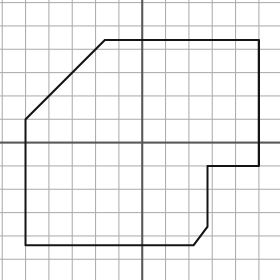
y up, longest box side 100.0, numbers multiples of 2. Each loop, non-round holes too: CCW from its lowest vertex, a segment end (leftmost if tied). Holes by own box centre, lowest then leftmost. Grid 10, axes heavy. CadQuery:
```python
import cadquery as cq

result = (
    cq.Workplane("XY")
    .moveTo(-50.0, -44.0)
    .lineTo(22.0, -44.0)
    .lineTo(28.0, -36.0)
    .lineTo(28.0, -10.0)
    .lineTo(50.0, -10.0)
    .lineTo(50.0, 44.0)
    .lineTo(-16.0, 44.0)
    .lineTo(-50.0, 10.0)
    .close()
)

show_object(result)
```